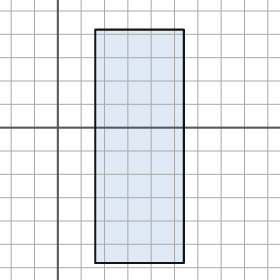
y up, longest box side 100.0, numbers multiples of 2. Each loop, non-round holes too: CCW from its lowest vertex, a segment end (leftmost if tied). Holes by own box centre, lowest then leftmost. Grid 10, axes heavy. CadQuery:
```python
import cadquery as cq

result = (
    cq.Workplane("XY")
    .moveTo(16.0, -58.0)
    .lineTo(54.0, -58.0)
    .lineTo(54.0, 42.0)
    .lineTo(16.0, 42.0)
    .close()
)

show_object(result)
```